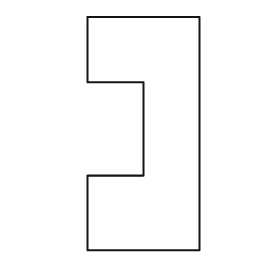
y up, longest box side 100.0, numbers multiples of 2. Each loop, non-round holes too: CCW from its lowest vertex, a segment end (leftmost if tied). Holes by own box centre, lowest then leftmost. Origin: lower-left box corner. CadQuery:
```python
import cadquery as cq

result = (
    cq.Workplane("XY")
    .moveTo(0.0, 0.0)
    .lineTo(48.0, 0.0)
    .lineTo(48.0, 100.0)
    .lineTo(0.0, 100.0)
    .lineTo(0.0, 72.0)
    .lineTo(24.0, 72.0)
    .lineTo(24.0, 32.0)
    .lineTo(0.0, 32.0)
    .close()
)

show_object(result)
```